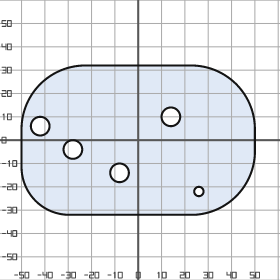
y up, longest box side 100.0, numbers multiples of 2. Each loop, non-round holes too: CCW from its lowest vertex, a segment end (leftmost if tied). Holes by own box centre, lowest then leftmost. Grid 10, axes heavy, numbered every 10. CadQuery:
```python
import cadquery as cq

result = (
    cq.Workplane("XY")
    .moveTo(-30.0, -32.0)
    .lineTo(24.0, -32.0)
    .threePointArc((42.0, -24.0), (50.0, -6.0))
    .lineTo(50.0, 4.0)
    .threePointArc((42.0, 24.0), (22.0, 32.0))
    .lineTo(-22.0, 32.0)
    .threePointArc((-42.0, 24.0), (-50.0, 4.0))
    .lineTo(-50.0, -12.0)
    .threePointArc((-44.0, -26.0), (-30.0, -32.0))
    .close()
    .moveTo(26.0, -22.0)
    .circle(2.0)
    .moveTo(-8.0, -14.0)
    .circle(4.0)
    .moveTo(-28.0, -4.0)
    .circle(4.0)
    .moveTo(-42.0, 6.0)
    .circle(4.0)
    .moveTo(14.0, 10.0)
    .circle(4.0)
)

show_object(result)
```